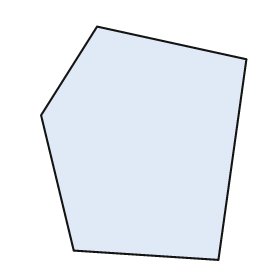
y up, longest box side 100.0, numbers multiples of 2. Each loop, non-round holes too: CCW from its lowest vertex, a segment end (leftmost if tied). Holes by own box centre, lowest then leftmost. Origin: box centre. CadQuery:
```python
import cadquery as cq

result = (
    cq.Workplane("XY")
    .moveTo(32.0, -50.0)
    .lineTo(44.0, 36.0)
    .lineTo(-20.0, 50.0)
    .lineTo(-44.0, 12.0)
    .lineTo(-30.0, -46.0)
    .close()
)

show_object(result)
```